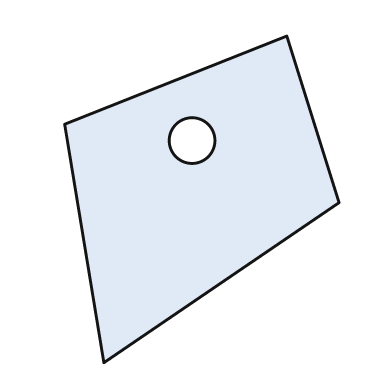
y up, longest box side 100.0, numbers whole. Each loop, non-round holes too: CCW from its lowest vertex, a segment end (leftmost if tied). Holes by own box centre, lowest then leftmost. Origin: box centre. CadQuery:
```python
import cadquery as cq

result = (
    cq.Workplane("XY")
    .moveTo(-30.0, -50.0)
    .lineTo(42.0, -1.0)
    .lineTo(26.0, 50.0)
    .lineTo(-42.0, 23.0)
    .close()
    .moveTo(-3.0, 18.0)
    .circle(7.0)
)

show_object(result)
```